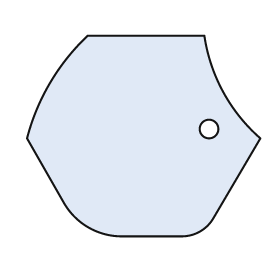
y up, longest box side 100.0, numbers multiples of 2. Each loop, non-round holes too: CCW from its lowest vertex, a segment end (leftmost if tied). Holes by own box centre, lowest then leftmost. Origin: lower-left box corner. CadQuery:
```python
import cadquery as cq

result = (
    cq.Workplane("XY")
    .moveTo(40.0, 0.0)
    .lineTo(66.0, 0.0)
    .threePointArc((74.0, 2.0), (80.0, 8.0))
    .lineTo(100.0, 42.0)
    .threePointArc((84.0, 62.0), (76.0, 86.0))
    .lineTo(26.0, 86.0)
    .threePointArc((10.0, 66.0), (0.0, 42.0))
    .lineTo(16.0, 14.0)
    .threePointArc((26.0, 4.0), (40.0, 0.0))
    .close()
    .moveTo(78.0, 46.0)
    .circle(4.0)
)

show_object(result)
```